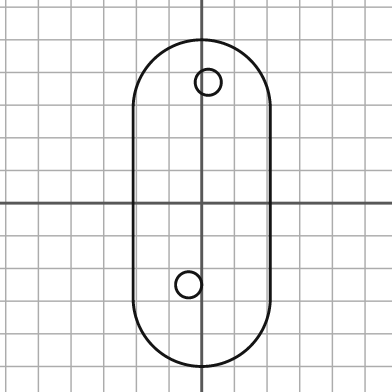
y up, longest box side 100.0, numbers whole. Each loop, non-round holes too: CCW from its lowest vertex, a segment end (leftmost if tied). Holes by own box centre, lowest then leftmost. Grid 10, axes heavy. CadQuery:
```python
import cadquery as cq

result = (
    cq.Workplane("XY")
    .moveTo(-21.0, -29.0)
    .threePointArc((0.0, -50.0), (21.0, -29.0))
    .lineTo(21.0, 29.0)
    .threePointArc((0.0, 50.0), (-21.0, 29.0))
    .close()
    .moveTo(-4.0, -25.0)
    .circle(4.0)
    .moveTo(2.0, 37.0)
    .circle(4.0)
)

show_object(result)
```